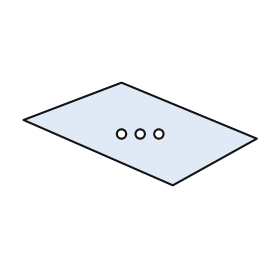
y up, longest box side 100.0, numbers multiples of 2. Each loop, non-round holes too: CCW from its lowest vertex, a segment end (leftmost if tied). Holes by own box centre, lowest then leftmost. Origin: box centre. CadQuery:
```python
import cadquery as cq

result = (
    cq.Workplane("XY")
    .moveTo(14.0, -22.0)
    .lineTo(50.0, -2.0)
    .lineTo(-8.0, 22.0)
    .lineTo(-50.0, 6.0)
    .close()
    .moveTo(-8.0, 0.0)
    .circle(2.0)
    .moveTo(0.0, 0.0)
    .circle(2.0)
    .moveTo(8.0, 0.0)
    .circle(2.0)
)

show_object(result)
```